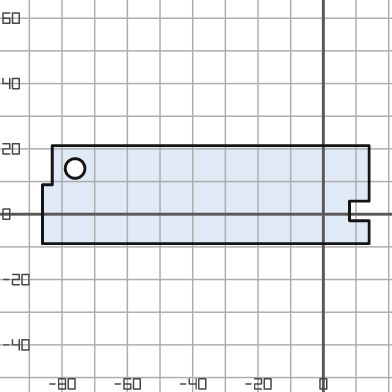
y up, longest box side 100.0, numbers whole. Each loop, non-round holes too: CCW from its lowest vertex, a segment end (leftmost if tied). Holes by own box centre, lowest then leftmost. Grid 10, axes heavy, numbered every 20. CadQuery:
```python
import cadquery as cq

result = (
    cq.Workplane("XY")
    .moveTo(-86.0, -9.0)
    .lineTo(14.0, -9.0)
    .lineTo(14.0, -2.0)
    .lineTo(8.0, -2.0)
    .lineTo(8.0, 4.0)
    .lineTo(14.0, 4.0)
    .lineTo(14.0, 21.0)
    .lineTo(-83.0, 21.0)
    .lineTo(-83.0, 9.0)
    .lineTo(-86.0, 9.0)
    .close()
    .moveTo(-76.0, 14.0)
    .circle(3.0)
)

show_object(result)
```